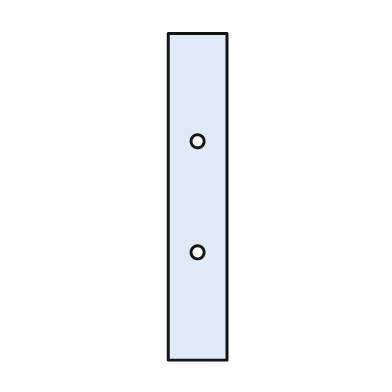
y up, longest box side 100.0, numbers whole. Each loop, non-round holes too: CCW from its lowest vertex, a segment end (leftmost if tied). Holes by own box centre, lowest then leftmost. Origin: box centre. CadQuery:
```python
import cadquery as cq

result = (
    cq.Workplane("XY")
    .moveTo(-9.0, -50.0)
    .lineTo(9.0, -50.0)
    .lineTo(9.0, 50.0)
    .lineTo(-9.0, 50.0)
    .close()
    .moveTo(0.0, -17.0)
    .circle(2.0)
    .moveTo(0.0, 17.0)
    .circle(2.0)
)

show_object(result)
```